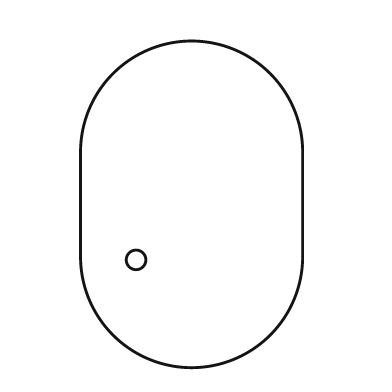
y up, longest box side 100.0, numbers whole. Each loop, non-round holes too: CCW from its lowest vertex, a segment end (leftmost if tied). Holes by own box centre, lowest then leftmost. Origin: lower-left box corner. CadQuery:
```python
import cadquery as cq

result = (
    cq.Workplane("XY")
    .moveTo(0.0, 34.0)
    .threePointArc((34.0, 0.0), (68.0, 34.0))
    .lineTo(68.0, 66.0)
    .threePointArc((34.0, 100.0), (0.0, 66.0))
    .close()
    .moveTo(17.0, 33.0)
    .circle(3.0)
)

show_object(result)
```